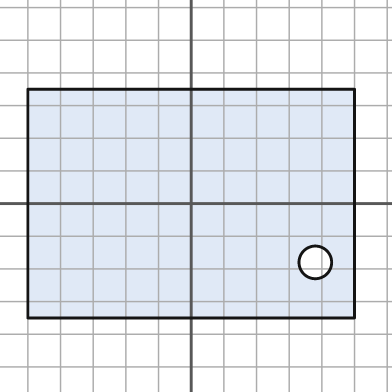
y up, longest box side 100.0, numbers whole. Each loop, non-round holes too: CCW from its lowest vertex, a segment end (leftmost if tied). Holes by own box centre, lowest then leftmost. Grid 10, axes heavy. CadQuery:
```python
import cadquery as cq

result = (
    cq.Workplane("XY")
    .moveTo(-50.0, -35.0)
    .lineTo(50.0, -35.0)
    .lineTo(50.0, 35.0)
    .lineTo(-50.0, 35.0)
    .close()
    .moveTo(38.0, -18.0)
    .circle(5.0)
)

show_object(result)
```